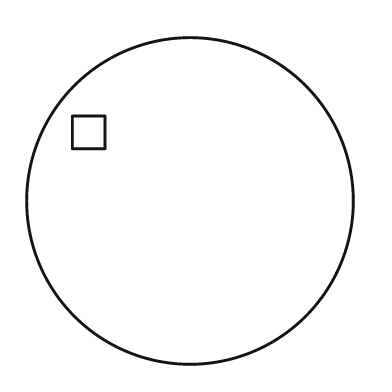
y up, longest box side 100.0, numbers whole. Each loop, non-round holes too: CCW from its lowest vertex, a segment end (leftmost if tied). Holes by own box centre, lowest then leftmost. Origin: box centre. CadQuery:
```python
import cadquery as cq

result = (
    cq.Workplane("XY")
    .moveTo(0.0, 0.0)
    .circle(50.0)
    .moveTo(-36.0, 16.0)
    .lineTo(-26.0, 16.0)
    .lineTo(-26.0, 26.0)
    .lineTo(-36.0, 26.0)
    .close()
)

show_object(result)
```